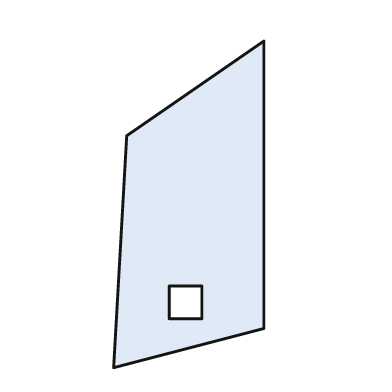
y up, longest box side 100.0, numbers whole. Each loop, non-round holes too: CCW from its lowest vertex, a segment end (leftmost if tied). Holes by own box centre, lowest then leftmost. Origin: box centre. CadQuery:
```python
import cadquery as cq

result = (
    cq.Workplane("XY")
    .moveTo(-23.0, -50.0)
    .lineTo(23.0, -38.0)
    .lineTo(23.0, 50.0)
    .lineTo(-19.0, 21.0)
    .close()
    .moveTo(-6.0, -35.0)
    .lineTo(4.0, -35.0)
    .lineTo(4.0, -25.0)
    .lineTo(-6.0, -25.0)
    .close()
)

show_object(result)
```